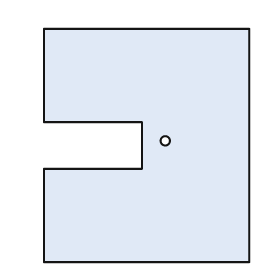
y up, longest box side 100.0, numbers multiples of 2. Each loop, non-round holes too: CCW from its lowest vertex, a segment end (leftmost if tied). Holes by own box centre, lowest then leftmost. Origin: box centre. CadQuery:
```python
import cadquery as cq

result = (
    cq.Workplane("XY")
    .moveTo(-44.0, -50.0)
    .lineTo(44.0, -50.0)
    .lineTo(44.0, 50.0)
    .lineTo(-44.0, 50.0)
    .lineTo(-44.0, 10.0)
    .lineTo(-2.0, 10.0)
    .lineTo(-2.0, -10.0)
    .lineTo(-44.0, -10.0)
    .close()
    .moveTo(8.0, 2.0)
    .circle(2.0)
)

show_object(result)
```